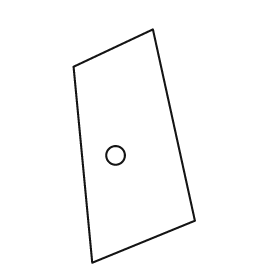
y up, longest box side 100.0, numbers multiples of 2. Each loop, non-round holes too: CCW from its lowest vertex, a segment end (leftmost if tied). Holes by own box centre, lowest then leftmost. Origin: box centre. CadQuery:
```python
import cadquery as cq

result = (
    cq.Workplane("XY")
    .moveTo(-18.0, -50.0)
    .lineTo(26.0, -32.0)
    .lineTo(8.0, 50.0)
    .lineTo(-26.0, 34.0)
    .close()
    .moveTo(-8.0, -4.0)
    .circle(4.0)
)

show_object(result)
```